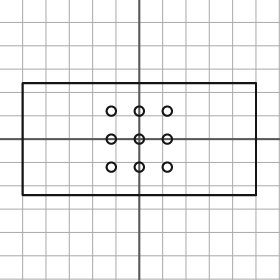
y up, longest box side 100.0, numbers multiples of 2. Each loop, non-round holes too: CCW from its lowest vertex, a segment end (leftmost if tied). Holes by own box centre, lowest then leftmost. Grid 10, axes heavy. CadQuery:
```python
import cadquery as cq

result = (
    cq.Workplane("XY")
    .moveTo(-50.0, -24.0)
    .lineTo(50.0, -24.0)
    .lineTo(50.0, 24.0)
    .lineTo(-50.0, 24.0)
    .close()
    .moveTo(-12.0, -12.0)
    .circle(2.0)
    .moveTo(0.0, -12.0)
    .circle(2.0)
    .moveTo(12.0, -12.0)
    .circle(2.0)
    .moveTo(-12.0, 0.0)
    .circle(2.0)
    .moveTo(0.0, 0.0)
    .circle(2.0)
    .moveTo(12.0, 0.0)
    .circle(2.0)
    .moveTo(-12.0, 12.0)
    .circle(2.0)
    .moveTo(0.0, 12.0)
    .circle(2.0)
    .moveTo(12.0, 12.0)
    .circle(2.0)
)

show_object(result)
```